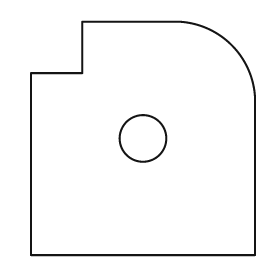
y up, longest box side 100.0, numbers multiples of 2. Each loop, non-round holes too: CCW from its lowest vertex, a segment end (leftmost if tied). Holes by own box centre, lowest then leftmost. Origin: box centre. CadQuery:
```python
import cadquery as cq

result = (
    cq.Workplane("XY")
    .moveTo(-48.0, -50.0)
    .lineTo(48.0, -50.0)
    .lineTo(48.0, 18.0)
    .threePointArc((38.0, 40.0), (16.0, 50.0))
    .lineTo(-26.0, 50.0)
    .lineTo(-26.0, 28.0)
    .lineTo(-48.0, 28.0)
    .close()
    .moveTo(0.0, 0.0)
    .circle(10.0)
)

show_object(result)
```